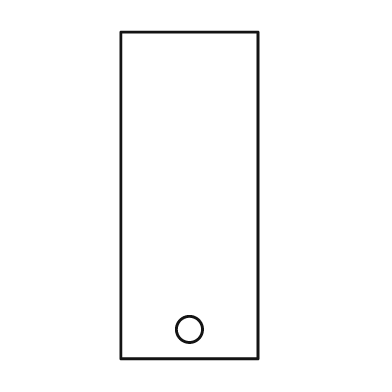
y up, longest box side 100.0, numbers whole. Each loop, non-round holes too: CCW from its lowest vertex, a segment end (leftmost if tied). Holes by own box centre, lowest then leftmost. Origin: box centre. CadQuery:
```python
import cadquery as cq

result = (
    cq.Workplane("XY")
    .moveTo(-21.0, -50.0)
    .lineTo(21.0, -50.0)
    .lineTo(21.0, 50.0)
    .lineTo(-21.0, 50.0)
    .close()
    .moveTo(0.0, -41.0)
    .circle(4.0)
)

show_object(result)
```